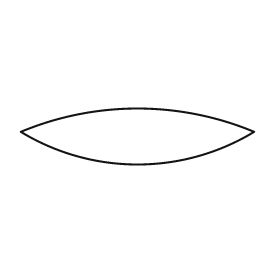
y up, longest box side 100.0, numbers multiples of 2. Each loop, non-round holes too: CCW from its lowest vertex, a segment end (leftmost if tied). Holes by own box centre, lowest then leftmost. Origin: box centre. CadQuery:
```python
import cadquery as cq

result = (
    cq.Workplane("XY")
    .moveTo(-50.0, 2.0)
    .threePointArc((0.0, -12.0), (50.0, 2.0))
    .threePointArc((0.0, 12.0), (-50.0, 2.0))
    .close()
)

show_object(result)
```